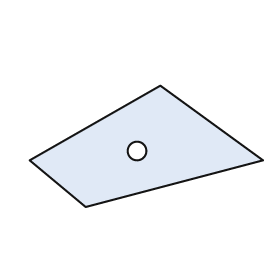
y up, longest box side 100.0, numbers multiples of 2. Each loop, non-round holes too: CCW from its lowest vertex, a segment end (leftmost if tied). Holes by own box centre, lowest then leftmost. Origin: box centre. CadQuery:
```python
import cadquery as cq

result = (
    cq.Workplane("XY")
    .moveTo(-26.0, -26.0)
    .lineTo(50.0, -6.0)
    .lineTo(6.0, 26.0)
    .lineTo(-50.0, -6.0)
    .close()
    .moveTo(-4.0, -2.0)
    .circle(4.0)
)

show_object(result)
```